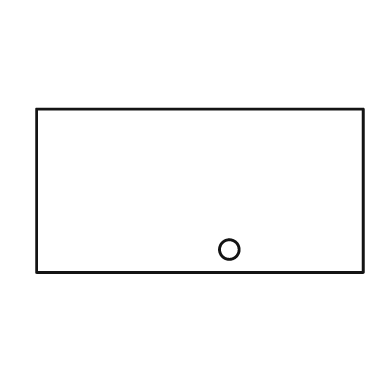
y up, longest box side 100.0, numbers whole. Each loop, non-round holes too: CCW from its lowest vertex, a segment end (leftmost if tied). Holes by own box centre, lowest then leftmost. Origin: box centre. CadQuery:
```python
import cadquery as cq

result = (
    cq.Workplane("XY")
    .moveTo(-50.0, -25.0)
    .lineTo(50.0, -25.0)
    .lineTo(50.0, 25.0)
    .lineTo(-50.0, 25.0)
    .close()
    .moveTo(9.0, -18.0)
    .circle(3.0)
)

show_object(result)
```